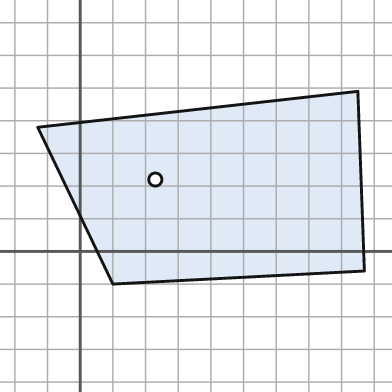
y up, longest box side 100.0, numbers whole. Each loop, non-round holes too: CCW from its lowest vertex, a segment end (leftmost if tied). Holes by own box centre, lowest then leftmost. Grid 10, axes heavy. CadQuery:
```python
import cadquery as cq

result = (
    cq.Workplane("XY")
    .moveTo(10.0, -10.0)
    .lineTo(87.0, -6.0)
    .lineTo(85.0, 49.0)
    .lineTo(-13.0, 38.0)
    .close()
    .moveTo(23.0, 22.0)
    .circle(2.0)
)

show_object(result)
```